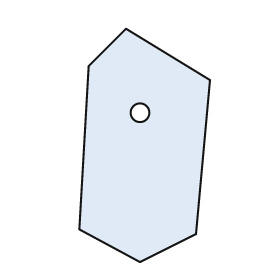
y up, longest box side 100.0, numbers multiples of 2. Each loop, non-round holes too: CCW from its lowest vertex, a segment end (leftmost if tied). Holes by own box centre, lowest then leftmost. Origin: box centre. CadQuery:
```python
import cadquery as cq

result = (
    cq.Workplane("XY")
    .moveTo(-2.0, -50.0)
    .lineTo(22.0, -38.0)
    .lineTo(28.0, 28.0)
    .lineTo(-8.0, 50.0)
    .lineTo(-24.0, 34.0)
    .lineTo(-28.0, -36.0)
    .close()
    .moveTo(-2.0, 14.0)
    .circle(4.0)
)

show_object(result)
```